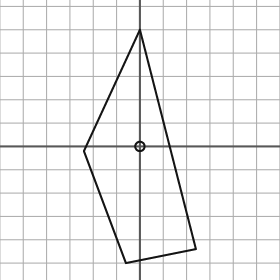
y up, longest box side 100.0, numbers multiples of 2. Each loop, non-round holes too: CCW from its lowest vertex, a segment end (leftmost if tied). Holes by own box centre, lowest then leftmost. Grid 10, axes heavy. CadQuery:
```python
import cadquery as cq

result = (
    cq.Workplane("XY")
    .moveTo(-6.0, -50.0)
    .lineTo(24.0, -44.0)
    .lineTo(0.0, 50.0)
    .lineTo(-24.0, -2.0)
    .close()
    .moveTo(0.0, 0.0)
    .circle(2.0)
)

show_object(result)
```